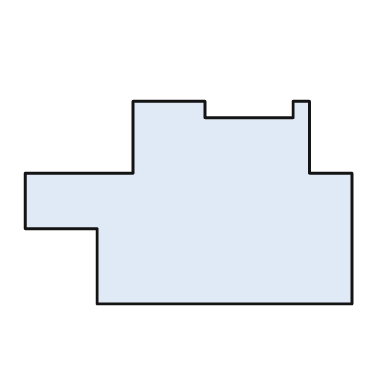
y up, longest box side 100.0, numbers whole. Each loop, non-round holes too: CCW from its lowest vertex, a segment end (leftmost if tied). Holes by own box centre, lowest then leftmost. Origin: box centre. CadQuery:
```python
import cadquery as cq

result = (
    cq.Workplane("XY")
    .moveTo(-28.0, -31.0)
    .lineTo(50.0, -31.0)
    .lineTo(50.0, 9.0)
    .lineTo(37.0, 9.0)
    .lineTo(37.0, 31.0)
    .lineTo(32.0, 31.0)
    .lineTo(32.0, 26.0)
    .lineTo(5.0, 26.0)
    .lineTo(5.0, 31.0)
    .lineTo(-17.0, 31.0)
    .lineTo(-17.0, 9.0)
    .lineTo(-50.0, 9.0)
    .lineTo(-50.0, -8.0)
    .lineTo(-28.0, -8.0)
    .close()
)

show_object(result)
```